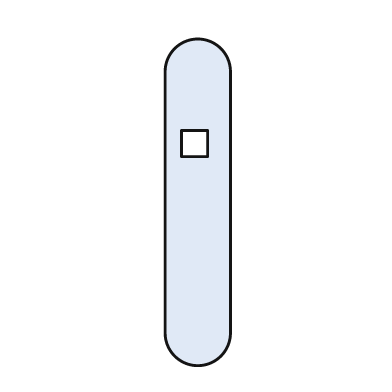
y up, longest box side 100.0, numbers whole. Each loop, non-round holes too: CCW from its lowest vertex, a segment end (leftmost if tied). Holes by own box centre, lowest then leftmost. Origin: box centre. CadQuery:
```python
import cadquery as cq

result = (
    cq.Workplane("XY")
    .moveTo(-10.0, -40.0)
    .threePointArc((0.0, -50.0), (10.0, -40.0))
    .lineTo(10.0, 40.0)
    .threePointArc((0.0, 50.0), (-10.0, 40.0))
    .close()
    .moveTo(-5.0, 14.0)
    .lineTo(3.0, 14.0)
    .lineTo(3.0, 22.0)
    .lineTo(-5.0, 22.0)
    .close()
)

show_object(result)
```